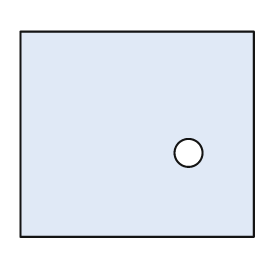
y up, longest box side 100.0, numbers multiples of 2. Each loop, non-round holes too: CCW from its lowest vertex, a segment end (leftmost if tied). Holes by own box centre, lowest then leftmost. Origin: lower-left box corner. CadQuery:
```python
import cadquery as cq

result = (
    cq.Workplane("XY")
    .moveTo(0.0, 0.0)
    .lineTo(100.0, 0.0)
    .lineTo(100.0, 88.0)
    .lineTo(0.0, 88.0)
    .close()
    .moveTo(72.0, 36.0)
    .circle(6.0)
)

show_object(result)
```